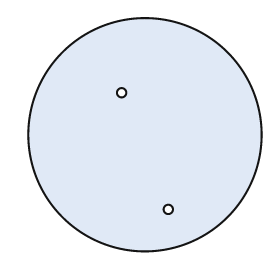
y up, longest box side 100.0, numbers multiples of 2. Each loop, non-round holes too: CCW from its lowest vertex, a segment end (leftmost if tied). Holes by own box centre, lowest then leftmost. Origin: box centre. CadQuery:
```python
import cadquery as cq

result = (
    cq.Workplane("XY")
    .moveTo(0.0, 0.0)
    .circle(50.0)
    .moveTo(10.0, -32.0)
    .circle(2.0)
    .moveTo(-10.0, 18.0)
    .circle(2.0)
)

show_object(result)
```